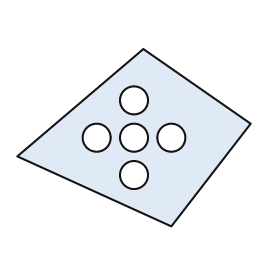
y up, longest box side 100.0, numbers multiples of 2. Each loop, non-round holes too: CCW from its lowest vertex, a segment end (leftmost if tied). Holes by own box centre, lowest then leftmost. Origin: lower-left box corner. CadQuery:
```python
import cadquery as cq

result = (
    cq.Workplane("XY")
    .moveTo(66.0, 0.0)
    .lineTo(100.0, 44.0)
    .lineTo(54.0, 76.0)
    .lineTo(0.0, 30.0)
    .close()
    .moveTo(50.0, 22.0)
    .circle(6.0)
    .moveTo(34.0, 38.0)
    .circle(6.0)
    .moveTo(50.0, 38.0)
    .circle(6.0)
    .moveTo(66.0, 38.0)
    .circle(6.0)
    .moveTo(50.0, 54.0)
    .circle(6.0)
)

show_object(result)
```